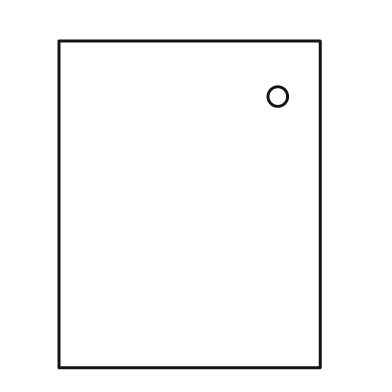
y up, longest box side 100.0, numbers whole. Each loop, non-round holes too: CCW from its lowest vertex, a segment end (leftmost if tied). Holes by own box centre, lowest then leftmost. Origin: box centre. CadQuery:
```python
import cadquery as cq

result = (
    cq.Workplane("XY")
    .moveTo(-40.0, -50.0)
    .lineTo(40.0, -50.0)
    .lineTo(40.0, 50.0)
    .lineTo(-40.0, 50.0)
    .close()
    .moveTo(27.0, 33.0)
    .circle(3.0)
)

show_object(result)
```